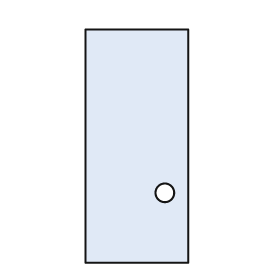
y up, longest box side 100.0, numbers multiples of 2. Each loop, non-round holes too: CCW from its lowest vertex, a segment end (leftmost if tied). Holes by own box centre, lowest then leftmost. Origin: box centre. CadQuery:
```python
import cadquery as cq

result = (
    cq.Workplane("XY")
    .moveTo(-22.0, -50.0)
    .lineTo(22.0, -50.0)
    .lineTo(22.0, 50.0)
    .lineTo(-22.0, 50.0)
    .close()
    .moveTo(12.0, -20.0)
    .circle(4.0)
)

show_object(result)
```